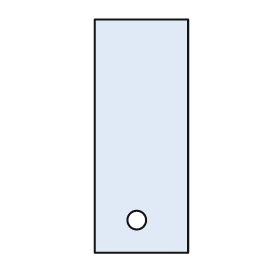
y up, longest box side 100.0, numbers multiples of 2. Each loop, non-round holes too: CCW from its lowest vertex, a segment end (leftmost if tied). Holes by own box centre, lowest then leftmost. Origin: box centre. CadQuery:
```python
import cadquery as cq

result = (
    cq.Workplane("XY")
    .moveTo(-20.0, -50.0)
    .lineTo(20.0, -50.0)
    .lineTo(20.0, 50.0)
    .lineTo(-20.0, 50.0)
    .close()
    .moveTo(-2.0, -36.0)
    .circle(4.0)
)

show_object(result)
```